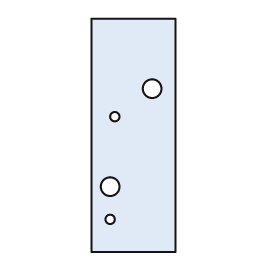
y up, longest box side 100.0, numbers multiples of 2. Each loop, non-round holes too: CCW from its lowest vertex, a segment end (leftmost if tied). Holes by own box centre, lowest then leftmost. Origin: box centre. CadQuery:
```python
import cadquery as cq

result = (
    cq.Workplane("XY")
    .moveTo(-18.0, -50.0)
    .lineTo(18.0, -50.0)
    .lineTo(18.0, 50.0)
    .lineTo(-18.0, 50.0)
    .close()
    .moveTo(-10.0, -36.0)
    .circle(2.0)
    .moveTo(-10.0, -22.0)
    .circle(4.0)
    .moveTo(-8.0, 8.0)
    .circle(2.0)
    .moveTo(8.0, 20.0)
    .circle(4.0)
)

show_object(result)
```